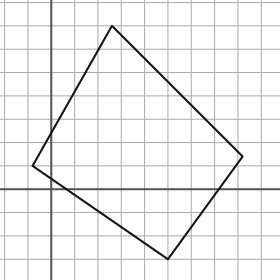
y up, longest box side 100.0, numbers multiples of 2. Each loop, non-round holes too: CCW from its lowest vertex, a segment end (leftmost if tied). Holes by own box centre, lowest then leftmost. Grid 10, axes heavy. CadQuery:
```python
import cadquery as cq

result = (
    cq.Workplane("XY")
    .moveTo(50.0, -30.0)
    .lineTo(82.0, 14.0)
    .lineTo(26.0, 70.0)
    .lineTo(-8.0, 10.0)
    .close()
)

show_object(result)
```